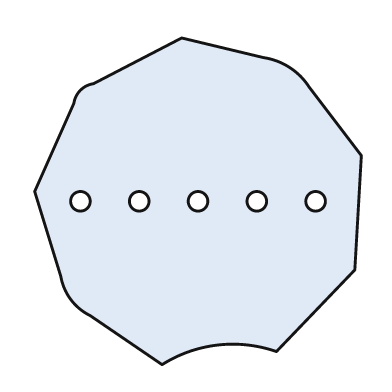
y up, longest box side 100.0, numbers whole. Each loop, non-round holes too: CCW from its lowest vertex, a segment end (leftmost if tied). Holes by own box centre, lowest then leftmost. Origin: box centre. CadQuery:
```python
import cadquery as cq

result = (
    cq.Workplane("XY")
    .moveTo(-11.0, -50.0)
    .threePointArc((6.0, -44.0), (24.0, -46.0))
    .lineTo(48.0, -21.0)
    .lineTo(50.0, 14.0)
    .lineTo(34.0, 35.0)
    .threePointArc((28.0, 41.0), (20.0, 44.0))
    .lineTo(-5.0, 50.0)
    .lineTo(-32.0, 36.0)
    .threePointArc((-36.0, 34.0), (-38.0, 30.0))
    .lineTo(-50.0, 3.0)
    .lineTo(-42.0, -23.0)
    .threePointArc((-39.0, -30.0), (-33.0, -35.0))
    .close()
    .moveTo(-36.0, 0.0)
    .circle(3.0)
    .moveTo(-18.0, 0.0)
    .circle(3.0)
    .moveTo(0.0, 0.0)
    .circle(3.0)
    .moveTo(18.0, 0.0)
    .circle(3.0)
    .moveTo(36.0, 0.0)
    .circle(3.0)
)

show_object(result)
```